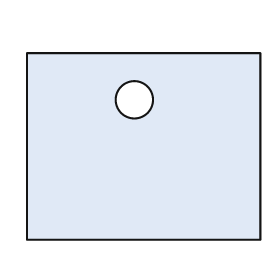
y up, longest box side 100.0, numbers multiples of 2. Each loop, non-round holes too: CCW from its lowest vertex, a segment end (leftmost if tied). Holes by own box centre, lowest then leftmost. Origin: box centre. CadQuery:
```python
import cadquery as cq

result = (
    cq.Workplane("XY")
    .moveTo(-50.0, -40.0)
    .lineTo(50.0, -40.0)
    .lineTo(50.0, 40.0)
    .lineTo(-50.0, 40.0)
    .close()
    .moveTo(-4.0, 20.0)
    .circle(8.0)
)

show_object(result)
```